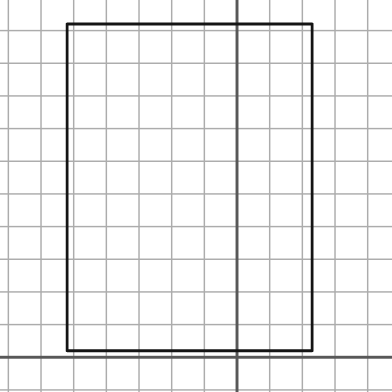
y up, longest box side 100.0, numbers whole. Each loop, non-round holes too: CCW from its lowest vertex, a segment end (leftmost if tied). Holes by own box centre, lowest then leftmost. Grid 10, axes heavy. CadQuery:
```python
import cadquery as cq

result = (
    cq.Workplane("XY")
    .moveTo(-52.0, 2.0)
    .lineTo(23.0, 2.0)
    .lineTo(23.0, 102.0)
    .lineTo(-52.0, 102.0)
    .close()
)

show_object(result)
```